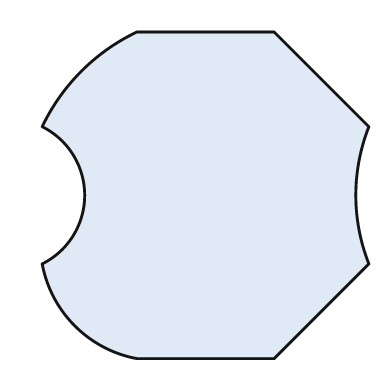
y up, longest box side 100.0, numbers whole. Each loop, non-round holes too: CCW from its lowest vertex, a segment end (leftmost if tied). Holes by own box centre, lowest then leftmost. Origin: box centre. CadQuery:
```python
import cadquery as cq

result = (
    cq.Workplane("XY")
    .moveTo(-21.0, -50.0)
    .lineTo(21.0, -50.0)
    .lineTo(50.0, -21.0)
    .threePointArc((46.0, 0.0), (50.0, 21.0))
    .lineTo(21.0, 50.0)
    .lineTo(-21.0, 50.0)
    .threePointArc((-38.0, 38.0), (-50.0, 21.0))
    .threePointArc((-37.0, 0.0), (-50.0, -21.0))
    .threePointArc((-40.0, -40.0), (-21.0, -50.0))
    .close()
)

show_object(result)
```